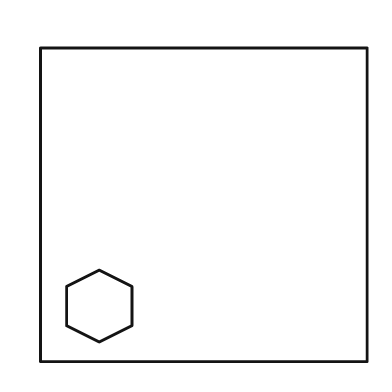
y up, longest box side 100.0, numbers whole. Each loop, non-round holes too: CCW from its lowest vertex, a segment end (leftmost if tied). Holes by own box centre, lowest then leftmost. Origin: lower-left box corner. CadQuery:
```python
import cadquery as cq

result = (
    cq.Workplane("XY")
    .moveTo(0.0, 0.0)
    .lineTo(100.0, 0.0)
    .lineTo(100.0, 96.0)
    .lineTo(0.0, 96.0)
    .close()
    .moveTo(18.0, 6.0)
    .lineTo(28.0, 11.0)
    .lineTo(28.0, 23.0)
    .lineTo(18.0, 28.0)
    .lineTo(8.0, 23.0)
    .lineTo(8.0, 11.0)
    .close()
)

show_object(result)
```